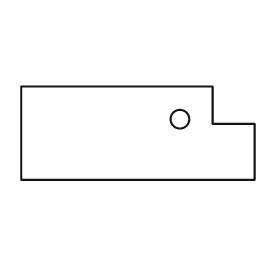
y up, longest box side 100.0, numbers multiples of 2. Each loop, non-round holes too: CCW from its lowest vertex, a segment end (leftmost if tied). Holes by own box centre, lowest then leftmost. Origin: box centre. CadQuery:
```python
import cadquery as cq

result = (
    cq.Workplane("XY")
    .moveTo(-50.0, -20.0)
    .lineTo(50.0, -20.0)
    .lineTo(50.0, 4.0)
    .lineTo(32.0, 4.0)
    .lineTo(32.0, 20.0)
    .lineTo(-50.0, 20.0)
    .close()
    .moveTo(18.0, 6.0)
    .circle(4.0)
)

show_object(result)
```